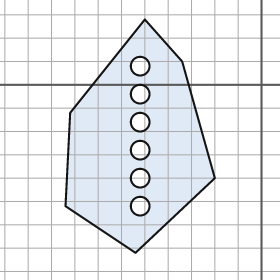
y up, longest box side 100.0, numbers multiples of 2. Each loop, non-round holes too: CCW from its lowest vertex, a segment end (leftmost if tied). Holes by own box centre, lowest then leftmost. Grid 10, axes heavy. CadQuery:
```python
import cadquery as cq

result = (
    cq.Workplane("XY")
    .moveTo(-54.0, -72.0)
    .lineTo(-20.0, -40.0)
    .lineTo(-34.0, 10.0)
    .lineTo(-50.0, 28.0)
    .lineTo(-82.0, -12.0)
    .lineTo(-84.0, -52.0)
    .close()
    .moveTo(-52.0, -52.0)
    .circle(4.0)
    .moveTo(-52.0, -40.0)
    .circle(4.0)
    .moveTo(-52.0, -28.0)
    .circle(4.0)
    .moveTo(-52.0, -16.0)
    .circle(4.0)
    .moveTo(-52.0, -4.0)
    .circle(4.0)
    .moveTo(-52.0, 8.0)
    .circle(4.0)
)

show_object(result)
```